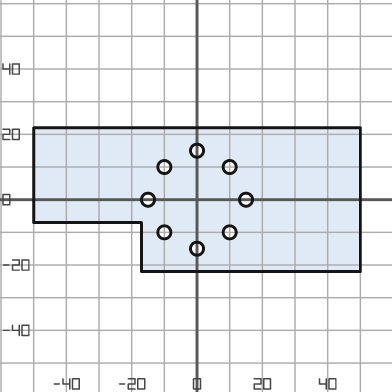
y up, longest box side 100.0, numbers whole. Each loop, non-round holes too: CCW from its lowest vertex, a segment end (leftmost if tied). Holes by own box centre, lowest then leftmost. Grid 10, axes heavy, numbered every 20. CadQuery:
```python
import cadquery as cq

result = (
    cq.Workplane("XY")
    .moveTo(-17.0, -22.0)
    .lineTo(50.0, -22.0)
    .lineTo(50.0, 22.0)
    .lineTo(-50.0, 22.0)
    .lineTo(-50.0, -7.0)
    .lineTo(-17.0, -7.0)
    .close()
    .moveTo(0.0, -15.0)
    .circle(2.0)
    .moveTo(-10.0, -10.0)
    .circle(2.0)
    .moveTo(10.0, -10.0)
    .circle(2.0)
    .moveTo(-15.0, 0.0)
    .circle(2.0)
    .moveTo(15.0, 0.0)
    .circle(2.0)
    .moveTo(-10.0, 10.0)
    .circle(2.0)
    .moveTo(10.0, 10.0)
    .circle(2.0)
    .moveTo(0.0, 15.0)
    .circle(2.0)
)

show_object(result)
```